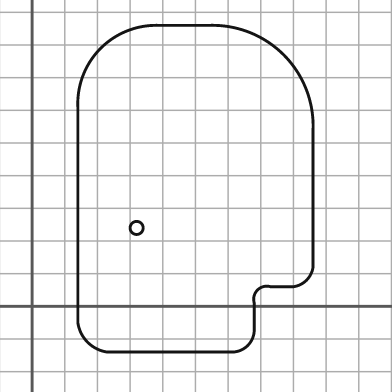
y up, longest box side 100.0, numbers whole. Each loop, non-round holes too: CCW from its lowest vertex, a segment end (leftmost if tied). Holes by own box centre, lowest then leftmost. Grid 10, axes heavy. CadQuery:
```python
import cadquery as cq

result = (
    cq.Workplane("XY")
    .moveTo(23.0, -14.0)
    .lineTo(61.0, -14.0)
    .threePointArc((66.0, -12.0), (68.0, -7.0))
    .lineTo(68.0, 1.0)
    .threePointArc((69.0, 5.0), (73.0, 6.0))
    .lineTo(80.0, 6.0)
    .threePointArc((84.0, 8.0), (86.0, 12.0))
    .lineTo(86.0, 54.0)
    .threePointArc((77.0, 77.0), (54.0, 86.0))
    .lineTo(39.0, 86.0)
    .threePointArc((21.0, 79.0), (14.0, 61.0))
    .lineTo(14.0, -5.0)
    .threePointArc((17.0, -11.0), (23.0, -14.0))
    .close()
    .moveTo(32.0, 24.0)
    .circle(2.0)
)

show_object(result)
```